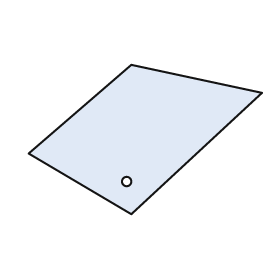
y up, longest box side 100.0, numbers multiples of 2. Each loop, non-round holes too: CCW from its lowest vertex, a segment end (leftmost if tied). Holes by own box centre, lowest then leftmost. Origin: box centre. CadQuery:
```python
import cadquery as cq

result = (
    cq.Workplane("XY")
    .moveTo(-6.0, -32.0)
    .lineTo(50.0, 20.0)
    .lineTo(-6.0, 32.0)
    .lineTo(-50.0, -6.0)
    .close()
    .moveTo(-8.0, -18.0)
    .circle(2.0)
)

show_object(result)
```